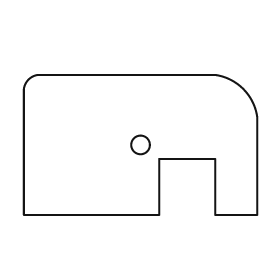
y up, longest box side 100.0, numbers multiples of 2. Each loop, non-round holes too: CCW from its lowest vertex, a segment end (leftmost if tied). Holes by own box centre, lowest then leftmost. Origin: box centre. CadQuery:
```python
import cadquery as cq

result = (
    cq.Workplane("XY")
    .moveTo(-50.0, -30.0)
    .lineTo(8.0, -30.0)
    .lineTo(8.0, -6.0)
    .lineTo(32.0, -6.0)
    .lineTo(32.0, -30.0)
    .lineTo(50.0, -30.0)
    .lineTo(50.0, 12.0)
    .threePointArc((44.0, 24.0), (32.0, 30.0))
    .lineTo(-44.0, 30.0)
    .threePointArc((-48.0, 28.0), (-50.0, 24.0))
    .close()
    .moveTo(0.0, 0.0)
    .circle(4.0)
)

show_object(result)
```